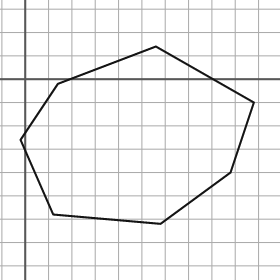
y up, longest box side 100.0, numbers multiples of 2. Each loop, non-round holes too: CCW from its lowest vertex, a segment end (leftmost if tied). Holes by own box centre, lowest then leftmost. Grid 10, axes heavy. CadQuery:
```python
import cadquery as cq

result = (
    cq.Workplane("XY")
    .moveTo(58.0, -62.0)
    .lineTo(88.0, -40.0)
    .lineTo(98.0, -10.0)
    .lineTo(56.0, 14.0)
    .lineTo(14.0, -2.0)
    .lineTo(-2.0, -26.0)
    .lineTo(12.0, -58.0)
    .close()
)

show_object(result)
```